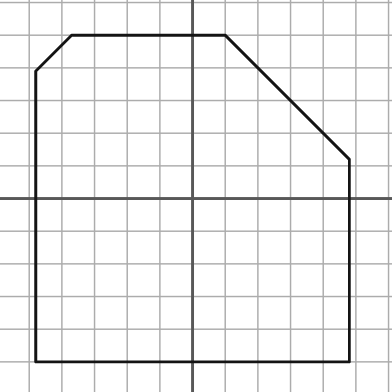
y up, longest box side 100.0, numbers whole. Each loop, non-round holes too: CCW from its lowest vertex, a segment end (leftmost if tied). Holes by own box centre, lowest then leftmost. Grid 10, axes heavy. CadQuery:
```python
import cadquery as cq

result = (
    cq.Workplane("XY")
    .moveTo(-48.0, -50.0)
    .lineTo(48.0, -50.0)
    .lineTo(48.0, 12.0)
    .lineTo(10.0, 50.0)
    .lineTo(-37.0, 50.0)
    .lineTo(-48.0, 39.0)
    .close()
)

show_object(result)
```